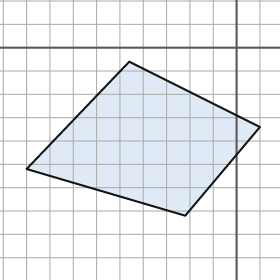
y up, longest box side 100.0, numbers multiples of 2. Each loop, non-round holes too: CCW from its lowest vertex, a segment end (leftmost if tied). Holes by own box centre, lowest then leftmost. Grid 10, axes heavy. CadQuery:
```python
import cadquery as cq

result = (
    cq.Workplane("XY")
    .moveTo(-22.0, -72.0)
    .lineTo(10.0, -34.0)
    .lineTo(-46.0, -6.0)
    .lineTo(-90.0, -52.0)
    .close()
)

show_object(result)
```